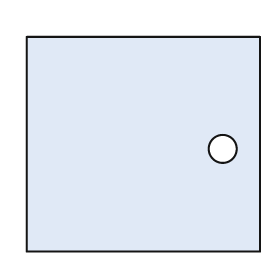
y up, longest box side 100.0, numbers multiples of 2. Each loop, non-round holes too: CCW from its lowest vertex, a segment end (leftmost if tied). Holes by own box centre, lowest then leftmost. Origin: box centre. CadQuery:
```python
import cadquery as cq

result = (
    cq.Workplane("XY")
    .moveTo(-50.0, -46.0)
    .lineTo(50.0, -46.0)
    .lineTo(50.0, 46.0)
    .lineTo(-50.0, 46.0)
    .close()
    .moveTo(34.0, -2.0)
    .circle(6.0)
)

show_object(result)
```